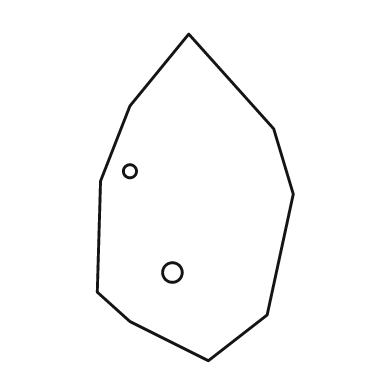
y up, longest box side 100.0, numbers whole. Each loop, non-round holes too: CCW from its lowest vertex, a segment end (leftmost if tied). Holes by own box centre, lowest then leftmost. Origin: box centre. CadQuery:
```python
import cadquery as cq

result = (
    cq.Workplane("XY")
    .moveTo(4.0, -50.0)
    .lineTo(22.0, -36.0)
    .lineTo(30.0, 1.0)
    .lineTo(24.0, 21.0)
    .lineTo(-2.0, 50.0)
    .lineTo(-20.0, 28.0)
    .lineTo(-29.0, 5.0)
    .lineTo(-30.0, -29.0)
    .lineTo(-20.0, -38.0)
    .close()
    .moveTo(-7.0, -23.0)
    .circle(3.0)
    .moveTo(-20.0, 8.0)
    .circle(2.0)
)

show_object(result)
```